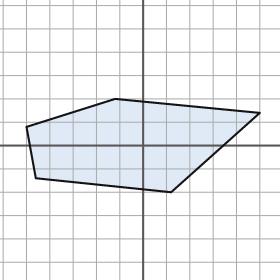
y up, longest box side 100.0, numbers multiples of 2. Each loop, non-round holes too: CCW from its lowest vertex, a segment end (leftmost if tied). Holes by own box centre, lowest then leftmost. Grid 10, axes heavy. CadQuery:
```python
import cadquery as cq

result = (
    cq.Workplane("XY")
    .moveTo(12.0, -20.0)
    .lineTo(50.0, 14.0)
    .lineTo(-12.0, 20.0)
    .lineTo(-50.0, 8.0)
    .lineTo(-46.0, -14.0)
    .close()
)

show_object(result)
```